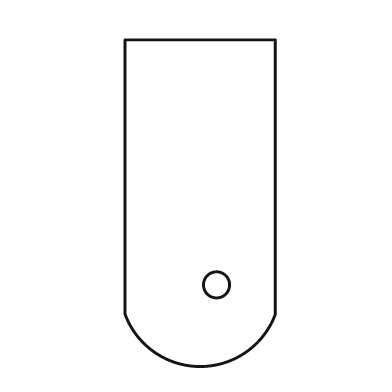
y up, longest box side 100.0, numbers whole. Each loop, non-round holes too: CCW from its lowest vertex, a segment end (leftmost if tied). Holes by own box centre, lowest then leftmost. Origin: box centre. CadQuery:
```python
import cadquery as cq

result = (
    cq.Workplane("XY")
    .moveTo(-23.0, -34.0)
    .threePointArc((0.0, -50.0), (23.0, -34.0))
    .lineTo(23.0, 50.0)
    .lineTo(-23.0, 50.0)
    .close()
    .moveTo(5.0, -25.0)
    .circle(4.0)
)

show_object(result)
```